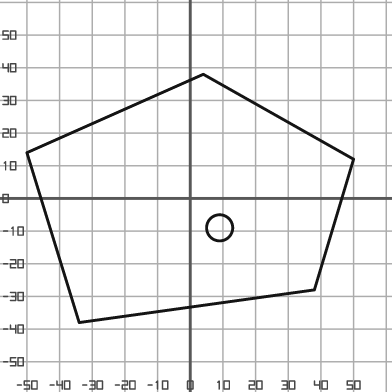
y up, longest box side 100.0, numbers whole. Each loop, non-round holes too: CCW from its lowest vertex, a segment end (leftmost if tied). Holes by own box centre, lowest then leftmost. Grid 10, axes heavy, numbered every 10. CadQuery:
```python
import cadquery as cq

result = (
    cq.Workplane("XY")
    .moveTo(-34.0, -38.0)
    .lineTo(38.0, -28.0)
    .lineTo(50.0, 12.0)
    .lineTo(4.0, 38.0)
    .lineTo(-50.0, 14.0)
    .close()
    .moveTo(9.0, -9.0)
    .circle(4.0)
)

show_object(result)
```